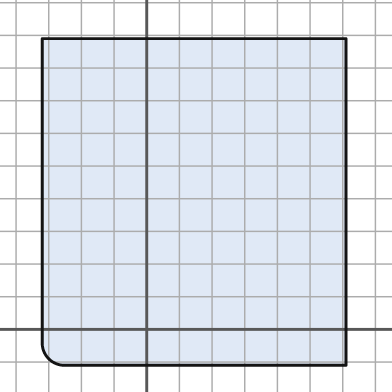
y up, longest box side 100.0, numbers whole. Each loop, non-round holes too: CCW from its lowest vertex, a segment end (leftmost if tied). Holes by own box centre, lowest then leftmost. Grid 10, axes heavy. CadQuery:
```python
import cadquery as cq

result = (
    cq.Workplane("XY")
    .moveTo(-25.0, -11.0)
    .lineTo(61.0, -11.0)
    .lineTo(61.0, 89.0)
    .lineTo(-32.0, 89.0)
    .lineTo(-32.0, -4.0)
    .threePointArc((-30.0, -9.0), (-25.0, -11.0))
    .close()
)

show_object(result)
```